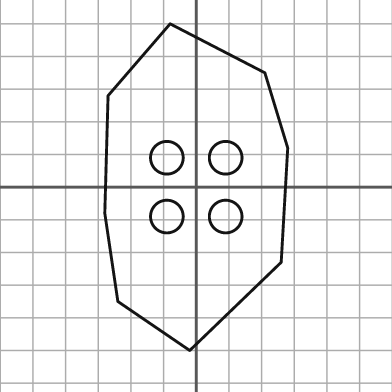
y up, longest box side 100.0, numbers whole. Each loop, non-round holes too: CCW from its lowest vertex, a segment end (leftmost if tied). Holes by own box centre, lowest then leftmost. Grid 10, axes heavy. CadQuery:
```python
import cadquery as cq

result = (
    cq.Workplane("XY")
    .moveTo(-2.0, -50.0)
    .lineTo(26.0, -23.0)
    .lineTo(28.0, 12.0)
    .lineTo(21.0, 35.0)
    .lineTo(-8.0, 50.0)
    .lineTo(-27.0, 28.0)
    .lineTo(-28.0, -8.0)
    .lineTo(-24.0, -35.0)
    .close()
    .moveTo(-9.0, -9.0)
    .circle(5.0)
    .moveTo(9.0, -9.0)
    .circle(5.0)
    .moveTo(-9.0, 9.0)
    .circle(5.0)
    .moveTo(9.0, 9.0)
    .circle(5.0)
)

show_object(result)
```